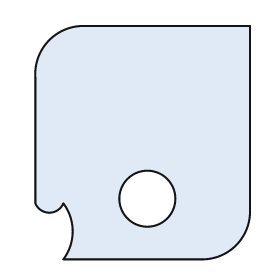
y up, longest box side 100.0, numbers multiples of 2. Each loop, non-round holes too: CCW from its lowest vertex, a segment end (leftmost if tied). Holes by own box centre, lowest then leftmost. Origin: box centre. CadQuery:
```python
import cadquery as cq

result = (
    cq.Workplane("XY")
    .moveTo(-34.0, -50.0)
    .lineTo(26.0, -50.0)
    .threePointArc((40.0, -44.0), (46.0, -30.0))
    .lineTo(46.0, 50.0)
    .lineTo(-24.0, 50.0)
    .threePointArc((-40.0, 44.0), (-46.0, 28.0))
    .lineTo(-46.0, -26.0)
    .threePointArc((-40.0, -30.0), (-34.0, -26.0))
    .threePointArc((-30.0, -38.0), (-34.0, -50.0))
    .close()
    .moveTo(2.0, -24.0)
    .circle(12.0)
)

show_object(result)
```